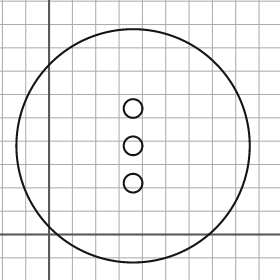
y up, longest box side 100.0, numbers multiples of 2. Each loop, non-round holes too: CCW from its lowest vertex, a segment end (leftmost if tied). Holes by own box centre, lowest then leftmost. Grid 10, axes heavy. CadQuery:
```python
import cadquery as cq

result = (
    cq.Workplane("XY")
    .moveTo(36.0, 38.0)
    .circle(50.0)
    .moveTo(36.0, 22.0)
    .circle(4.0)
    .moveTo(36.0, 38.0)
    .circle(4.0)
    .moveTo(36.0, 54.0)
    .circle(4.0)
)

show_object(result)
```